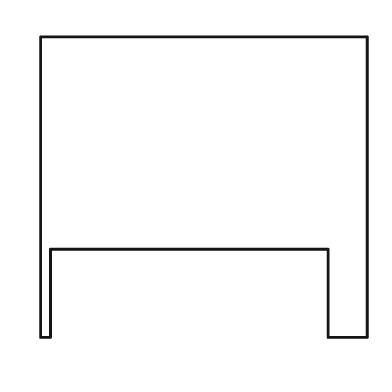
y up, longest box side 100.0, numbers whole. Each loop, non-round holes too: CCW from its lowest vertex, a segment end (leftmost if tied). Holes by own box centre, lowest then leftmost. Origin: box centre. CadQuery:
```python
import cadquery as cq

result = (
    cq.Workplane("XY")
    .moveTo(-50.0, -46.0)
    .lineTo(-47.0, -46.0)
    .lineTo(-47.0, -19.0)
    .lineTo(38.0, -19.0)
    .lineTo(38.0, -46.0)
    .lineTo(50.0, -46.0)
    .lineTo(50.0, 46.0)
    .lineTo(-50.0, 46.0)
    .close()
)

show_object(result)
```